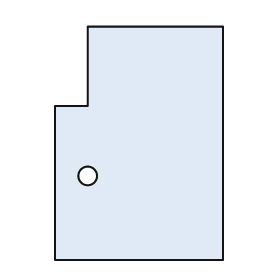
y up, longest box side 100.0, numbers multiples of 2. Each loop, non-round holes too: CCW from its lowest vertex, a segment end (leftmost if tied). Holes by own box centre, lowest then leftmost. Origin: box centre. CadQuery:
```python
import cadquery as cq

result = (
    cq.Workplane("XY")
    .moveTo(-36.0, -50.0)
    .lineTo(36.0, -50.0)
    .lineTo(36.0, 50.0)
    .lineTo(-22.0, 50.0)
    .lineTo(-22.0, 16.0)
    .lineTo(-36.0, 16.0)
    .close()
    .moveTo(-22.0, -14.0)
    .circle(4.0)
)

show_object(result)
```